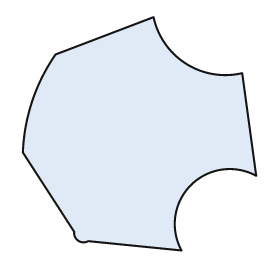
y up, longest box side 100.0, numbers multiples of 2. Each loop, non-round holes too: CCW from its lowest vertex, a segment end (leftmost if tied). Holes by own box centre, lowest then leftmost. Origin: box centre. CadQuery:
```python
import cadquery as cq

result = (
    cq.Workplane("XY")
    .moveTo(18.0, -50.0)
    .threePointArc((22.0, -22.0), (50.0, -18.0))
    .lineTo(44.0, 26.0)
    .threePointArc((20.0, 30.0), (6.0, 50.0))
    .lineTo(-36.0, 34.0)
    .threePointArc((-46.0, 14.0), (-50.0, -8.0))
    .lineTo(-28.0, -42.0)
    .threePointArc((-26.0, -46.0), (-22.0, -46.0))
    .close()
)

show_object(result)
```